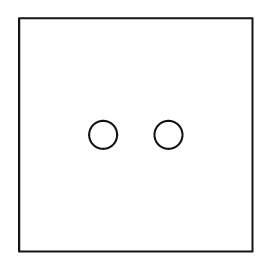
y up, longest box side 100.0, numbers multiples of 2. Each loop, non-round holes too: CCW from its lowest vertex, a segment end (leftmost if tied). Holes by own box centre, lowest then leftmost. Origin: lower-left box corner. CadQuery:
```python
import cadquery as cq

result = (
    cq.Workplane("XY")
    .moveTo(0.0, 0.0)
    .lineTo(100.0, 0.0)
    .lineTo(100.0, 100.0)
    .lineTo(0.0, 100.0)
    .close()
    .moveTo(36.0, 50.0)
    .circle(6.0)
    .moveTo(64.0, 50.0)
    .circle(6.0)
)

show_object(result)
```